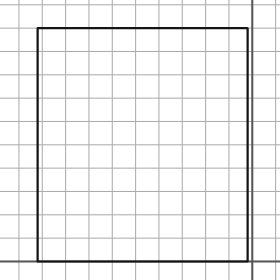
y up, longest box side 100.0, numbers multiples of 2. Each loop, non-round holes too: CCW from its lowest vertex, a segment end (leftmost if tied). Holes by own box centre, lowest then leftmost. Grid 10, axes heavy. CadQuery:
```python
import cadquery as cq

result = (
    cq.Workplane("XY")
    .moveTo(-92.0, 0.0)
    .lineTo(-2.0, 0.0)
    .lineTo(-2.0, 100.0)
    .lineTo(-92.0, 100.0)
    .close()
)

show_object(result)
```